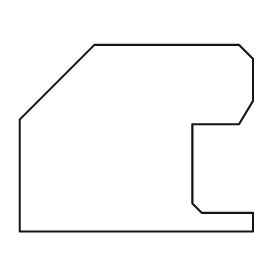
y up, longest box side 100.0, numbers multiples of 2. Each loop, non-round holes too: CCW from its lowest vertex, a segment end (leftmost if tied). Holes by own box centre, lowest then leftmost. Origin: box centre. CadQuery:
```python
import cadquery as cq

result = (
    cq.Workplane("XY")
    .moveTo(-50.0, -40.0)
    .lineTo(50.0, -40.0)
    .lineTo(50.0, -32.0)
    .lineTo(28.0, -32.0)
    .lineTo(24.0, -28.0)
    .lineTo(24.0, 6.0)
    .lineTo(44.0, 6.0)
    .lineTo(50.0, 16.0)
    .lineTo(50.0, 34.0)
    .lineTo(44.0, 40.0)
    .lineTo(-18.0, 40.0)
    .lineTo(-50.0, 8.0)
    .close()
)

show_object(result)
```